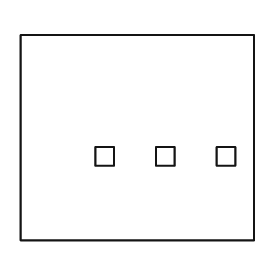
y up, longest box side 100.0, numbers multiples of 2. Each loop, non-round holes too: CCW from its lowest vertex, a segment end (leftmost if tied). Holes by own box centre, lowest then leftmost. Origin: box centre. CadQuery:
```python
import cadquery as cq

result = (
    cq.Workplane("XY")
    .moveTo(-50.0, -44.0)
    .lineTo(50.0, -44.0)
    .lineTo(50.0, 44.0)
    .lineTo(-50.0, 44.0)
    .close()
    .moveTo(-18.0, -12.0)
    .lineTo(-10.0, -12.0)
    .lineTo(-10.0, -4.0)
    .lineTo(-18.0, -4.0)
    .close()
    .moveTo(8.0, -12.0)
    .lineTo(16.0, -12.0)
    .lineTo(16.0, -4.0)
    .lineTo(8.0, -4.0)
    .close()
    .moveTo(34.0, -12.0)
    .lineTo(42.0, -12.0)
    .lineTo(42.0, -4.0)
    .lineTo(34.0, -4.0)
    .close()
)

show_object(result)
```